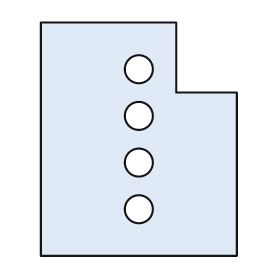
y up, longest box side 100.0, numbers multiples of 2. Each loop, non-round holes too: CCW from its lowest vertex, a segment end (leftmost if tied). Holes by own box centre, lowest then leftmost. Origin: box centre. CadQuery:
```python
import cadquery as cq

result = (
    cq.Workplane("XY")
    .moveTo(-42.0, -50.0)
    .lineTo(42.0, -50.0)
    .lineTo(42.0, 20.0)
    .lineTo(16.0, 20.0)
    .lineTo(16.0, 50.0)
    .lineTo(-42.0, 50.0)
    .close()
    .moveTo(0.0, -30.0)
    .circle(6.0)
    .moveTo(0.0, -10.0)
    .circle(6.0)
    .moveTo(0.0, 10.0)
    .circle(6.0)
    .moveTo(0.0, 30.0)
    .circle(6.0)
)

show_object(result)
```